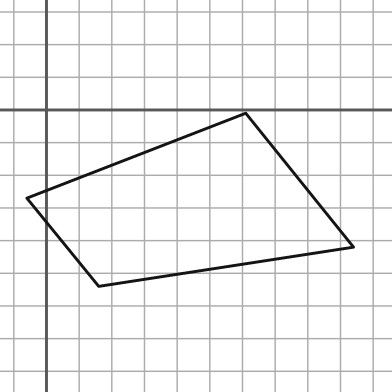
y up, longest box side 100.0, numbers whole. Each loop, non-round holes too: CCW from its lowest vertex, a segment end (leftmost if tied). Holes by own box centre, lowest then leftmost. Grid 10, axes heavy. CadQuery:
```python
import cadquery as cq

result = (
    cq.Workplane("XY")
    .moveTo(16.0, -54.0)
    .lineTo(94.0, -42.0)
    .lineTo(61.0, -1.0)
    .lineTo(-6.0, -27.0)
    .close()
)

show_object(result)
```